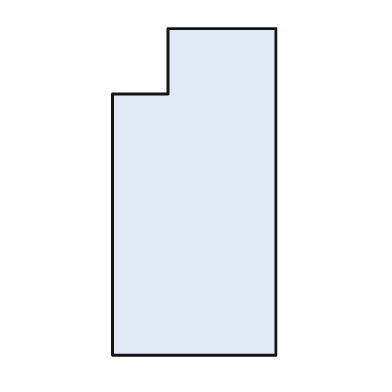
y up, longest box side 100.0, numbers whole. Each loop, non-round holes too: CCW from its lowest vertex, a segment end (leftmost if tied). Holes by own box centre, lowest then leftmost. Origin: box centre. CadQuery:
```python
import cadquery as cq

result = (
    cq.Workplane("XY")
    .moveTo(-25.0, -50.0)
    .lineTo(25.0, -50.0)
    .lineTo(25.0, 50.0)
    .lineTo(-8.0, 50.0)
    .lineTo(-8.0, 30.0)
    .lineTo(-25.0, 30.0)
    .close()
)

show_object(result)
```